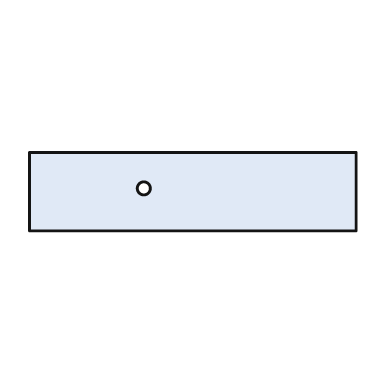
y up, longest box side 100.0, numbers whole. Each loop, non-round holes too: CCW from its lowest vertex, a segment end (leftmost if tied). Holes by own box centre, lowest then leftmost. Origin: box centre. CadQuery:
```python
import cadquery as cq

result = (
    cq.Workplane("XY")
    .moveTo(-50.0, -12.0)
    .lineTo(50.0, -12.0)
    .lineTo(50.0, 12.0)
    .lineTo(-50.0, 12.0)
    .close()
    .moveTo(-15.0, 1.0)
    .circle(2.0)
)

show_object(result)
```